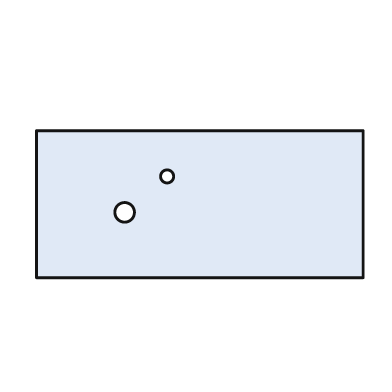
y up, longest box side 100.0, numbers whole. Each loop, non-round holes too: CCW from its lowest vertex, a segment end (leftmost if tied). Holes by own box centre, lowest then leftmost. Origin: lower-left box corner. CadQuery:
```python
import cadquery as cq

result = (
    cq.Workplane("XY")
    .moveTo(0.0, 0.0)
    .lineTo(100.0, 0.0)
    .lineTo(100.0, 45.0)
    .lineTo(0.0, 45.0)
    .close()
    .moveTo(27.0, 20.0)
    .circle(3.0)
    .moveTo(40.0, 31.0)
    .circle(2.0)
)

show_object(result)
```